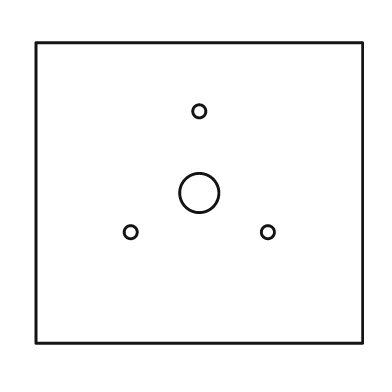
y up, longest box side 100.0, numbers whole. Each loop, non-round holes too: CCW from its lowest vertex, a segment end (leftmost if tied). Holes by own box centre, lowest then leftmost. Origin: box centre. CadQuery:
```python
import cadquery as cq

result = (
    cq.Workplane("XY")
    .moveTo(-50.0, -46.0)
    .lineTo(50.0, -46.0)
    .lineTo(50.0, 46.0)
    .lineTo(-50.0, 46.0)
    .close()
    .moveTo(-21.0, -12.0)
    .circle(2.0)
    .moveTo(21.0, -12.0)
    .circle(2.0)
    .moveTo(0.0, 0.0)
    .circle(6.0)
    .moveTo(0.0, 25.0)
    .circle(2.0)
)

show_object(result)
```